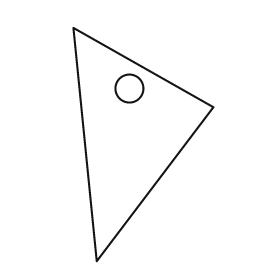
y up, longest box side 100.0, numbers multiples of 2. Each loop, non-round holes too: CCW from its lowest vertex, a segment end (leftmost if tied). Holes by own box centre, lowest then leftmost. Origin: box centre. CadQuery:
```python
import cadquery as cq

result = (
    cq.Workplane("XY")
    .moveTo(-20.0, -50.0)
    .lineTo(30.0, 16.0)
    .lineTo(-30.0, 50.0)
    .close()
    .moveTo(-6.0, 24.0)
    .circle(6.0)
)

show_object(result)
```